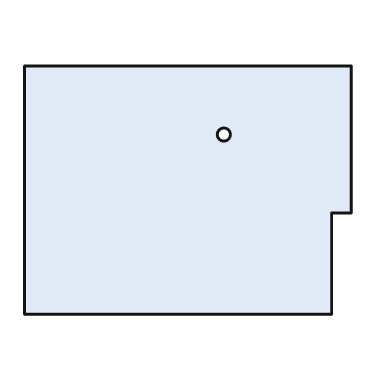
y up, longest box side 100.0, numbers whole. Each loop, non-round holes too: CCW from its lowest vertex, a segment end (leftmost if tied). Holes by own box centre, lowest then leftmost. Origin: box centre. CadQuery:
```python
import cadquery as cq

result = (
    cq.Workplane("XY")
    .moveTo(-50.0, -38.0)
    .lineTo(44.0, -38.0)
    .lineTo(44.0, -7.0)
    .lineTo(50.0, -7.0)
    .lineTo(50.0, 38.0)
    .lineTo(-50.0, 38.0)
    .close()
    .moveTo(11.0, 17.0)
    .circle(2.0)
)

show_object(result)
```